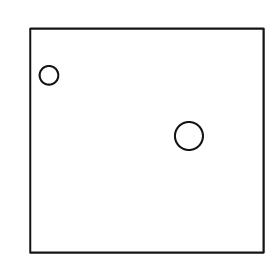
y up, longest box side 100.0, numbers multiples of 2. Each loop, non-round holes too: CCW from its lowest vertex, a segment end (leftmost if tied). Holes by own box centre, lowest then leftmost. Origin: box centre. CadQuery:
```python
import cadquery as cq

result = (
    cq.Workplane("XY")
    .moveTo(-50.0, -48.0)
    .lineTo(50.0, -48.0)
    .lineTo(50.0, 48.0)
    .lineTo(-50.0, 48.0)
    .close()
    .moveTo(18.0, 2.0)
    .circle(6.0)
    .moveTo(-42.0, 28.0)
    .circle(4.0)
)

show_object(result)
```